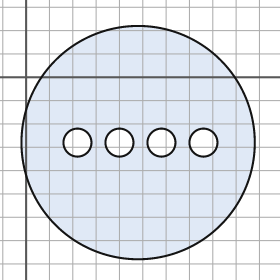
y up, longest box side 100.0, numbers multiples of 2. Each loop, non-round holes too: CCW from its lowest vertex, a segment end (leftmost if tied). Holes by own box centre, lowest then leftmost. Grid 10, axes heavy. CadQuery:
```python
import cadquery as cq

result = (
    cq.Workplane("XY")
    .moveTo(48.0, -28.0)
    .circle(50.0)
    .moveTo(22.0, -28.0)
    .circle(6.0)
    .moveTo(40.0, -28.0)
    .circle(6.0)
    .moveTo(58.0, -28.0)
    .circle(6.0)
    .moveTo(76.0, -28.0)
    .circle(6.0)
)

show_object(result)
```